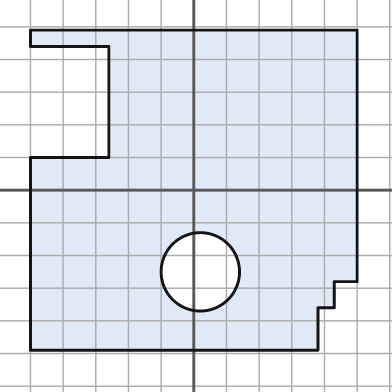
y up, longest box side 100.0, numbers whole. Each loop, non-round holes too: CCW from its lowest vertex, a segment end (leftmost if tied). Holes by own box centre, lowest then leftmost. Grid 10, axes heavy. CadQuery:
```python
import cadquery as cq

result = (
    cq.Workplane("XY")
    .moveTo(-50.0, -49.0)
    .lineTo(38.0, -49.0)
    .lineTo(38.0, -36.0)
    .lineTo(43.0, -36.0)
    .lineTo(43.0, -28.0)
    .lineTo(50.0, -28.0)
    .lineTo(50.0, 49.0)
    .lineTo(-50.0, 49.0)
    .lineTo(-50.0, 44.0)
    .lineTo(-26.0, 44.0)
    .lineTo(-26.0, 10.0)
    .lineTo(-50.0, 10.0)
    .close()
    .moveTo(2.0, -25.0)
    .circle(12.0)
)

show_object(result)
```